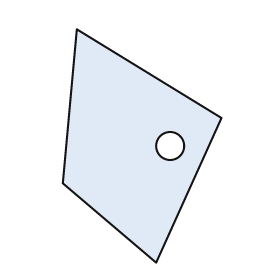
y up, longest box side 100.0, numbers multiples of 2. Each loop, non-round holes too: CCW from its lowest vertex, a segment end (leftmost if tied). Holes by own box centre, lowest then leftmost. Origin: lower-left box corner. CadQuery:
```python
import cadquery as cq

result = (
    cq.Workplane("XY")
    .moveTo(40.0, 0.0)
    .lineTo(68.0, 62.0)
    .lineTo(6.0, 100.0)
    .lineTo(0.0, 34.0)
    .close()
    .moveTo(46.0, 50.0)
    .circle(6.0)
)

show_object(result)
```